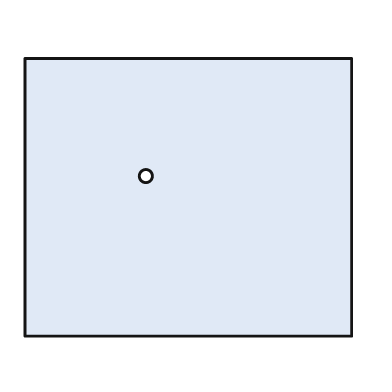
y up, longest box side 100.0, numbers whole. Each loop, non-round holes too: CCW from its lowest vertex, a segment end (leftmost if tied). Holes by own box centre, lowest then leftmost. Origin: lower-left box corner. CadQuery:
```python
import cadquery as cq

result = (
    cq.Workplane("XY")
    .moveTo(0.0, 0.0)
    .lineTo(100.0, 0.0)
    .lineTo(100.0, 85.0)
    .lineTo(0.0, 85.0)
    .close()
    .moveTo(37.0, 49.0)
    .circle(2.0)
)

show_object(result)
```